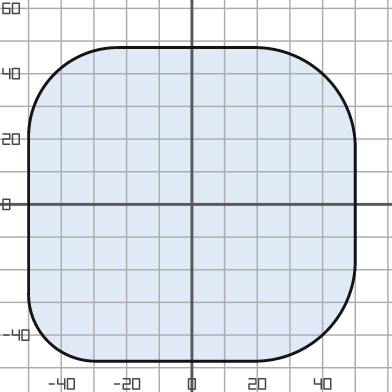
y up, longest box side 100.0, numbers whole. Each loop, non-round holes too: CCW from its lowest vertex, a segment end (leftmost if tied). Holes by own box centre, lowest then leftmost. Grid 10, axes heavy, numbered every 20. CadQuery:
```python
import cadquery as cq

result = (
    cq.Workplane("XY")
    .moveTo(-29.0, -48.0)
    .lineTo(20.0, -48.0)
    .threePointArc((41.0, -39.0), (50.0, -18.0))
    .lineTo(50.0, 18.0)
    .threePointArc((41.0, 39.0), (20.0, 48.0))
    .lineTo(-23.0, 48.0)
    .threePointArc((-42.0, 40.0), (-50.0, 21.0))
    .lineTo(-50.0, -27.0)
    .threePointArc((-44.0, -42.0), (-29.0, -48.0))
    .close()
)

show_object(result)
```